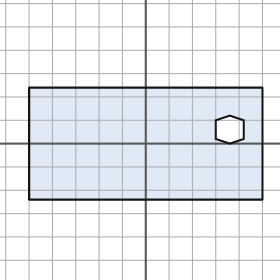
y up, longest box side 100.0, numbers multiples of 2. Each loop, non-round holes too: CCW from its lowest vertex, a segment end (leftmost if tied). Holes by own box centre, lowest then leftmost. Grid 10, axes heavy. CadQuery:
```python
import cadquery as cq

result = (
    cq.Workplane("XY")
    .moveTo(-50.0, -24.0)
    .lineTo(50.0, -24.0)
    .lineTo(50.0, 24.0)
    .lineTo(-50.0, 24.0)
    .close()
    .moveTo(36.0, 0.0)
    .lineTo(42.0, 2.0)
    .lineTo(42.0, 10.0)
    .lineTo(36.0, 12.0)
    .lineTo(30.0, 10.0)
    .lineTo(30.0, 2.0)
    .close()
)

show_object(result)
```